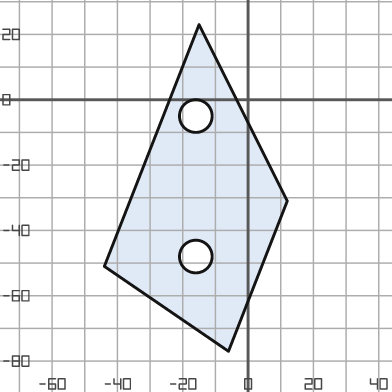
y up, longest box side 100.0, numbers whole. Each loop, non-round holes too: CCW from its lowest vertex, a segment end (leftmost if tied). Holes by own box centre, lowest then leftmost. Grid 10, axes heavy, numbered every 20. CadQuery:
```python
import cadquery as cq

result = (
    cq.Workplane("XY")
    .moveTo(-6.0, -77.0)
    .lineTo(12.0, -31.0)
    .lineTo(-15.0, 23.0)
    .lineTo(-44.0, -51.0)
    .close()
    .moveTo(-16.0, -48.0)
    .circle(5.0)
    .moveTo(-16.0, -5.0)
    .circle(5.0)
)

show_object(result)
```